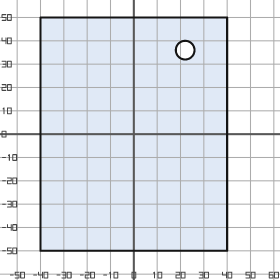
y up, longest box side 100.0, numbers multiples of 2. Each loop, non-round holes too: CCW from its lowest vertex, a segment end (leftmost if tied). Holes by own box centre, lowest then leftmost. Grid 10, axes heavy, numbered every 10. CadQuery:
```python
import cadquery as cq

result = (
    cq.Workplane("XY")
    .moveTo(-40.0, -50.0)
    .lineTo(40.0, -50.0)
    .lineTo(40.0, 50.0)
    .lineTo(-40.0, 50.0)
    .close()
    .moveTo(22.0, 36.0)
    .circle(4.0)
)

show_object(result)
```